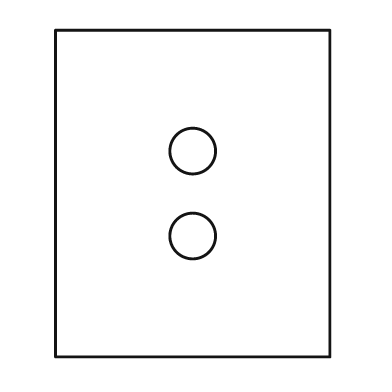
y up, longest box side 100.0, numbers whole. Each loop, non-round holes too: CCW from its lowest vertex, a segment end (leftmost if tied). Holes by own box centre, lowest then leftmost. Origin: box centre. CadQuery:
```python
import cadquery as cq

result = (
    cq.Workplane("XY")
    .moveTo(-42.0, -50.0)
    .lineTo(42.0, -50.0)
    .lineTo(42.0, 50.0)
    .lineTo(-42.0, 50.0)
    .close()
    .moveTo(0.0, -13.0)
    .circle(7.0)
    .moveTo(0.0, 13.0)
    .circle(7.0)
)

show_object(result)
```